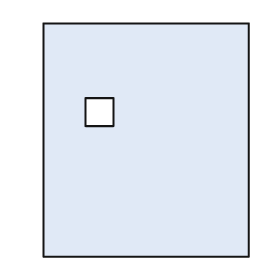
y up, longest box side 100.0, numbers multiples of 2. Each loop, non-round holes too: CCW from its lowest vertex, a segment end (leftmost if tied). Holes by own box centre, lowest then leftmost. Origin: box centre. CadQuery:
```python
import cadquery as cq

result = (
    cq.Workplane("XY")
    .moveTo(-44.0, -50.0)
    .lineTo(44.0, -50.0)
    .lineTo(44.0, 50.0)
    .lineTo(-44.0, 50.0)
    .close()
    .moveTo(-26.0, 6.0)
    .lineTo(-14.0, 6.0)
    .lineTo(-14.0, 18.0)
    .lineTo(-26.0, 18.0)
    .close()
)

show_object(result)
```